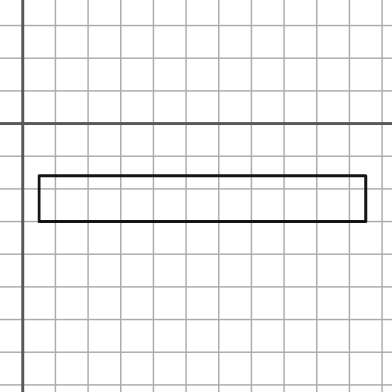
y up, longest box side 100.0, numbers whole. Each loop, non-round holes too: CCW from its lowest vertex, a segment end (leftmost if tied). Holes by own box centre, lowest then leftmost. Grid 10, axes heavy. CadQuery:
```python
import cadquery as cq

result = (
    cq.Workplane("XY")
    .moveTo(5.0, -30.0)
    .lineTo(105.0, -30.0)
    .lineTo(105.0, -16.0)
    .lineTo(5.0, -16.0)
    .close()
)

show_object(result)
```